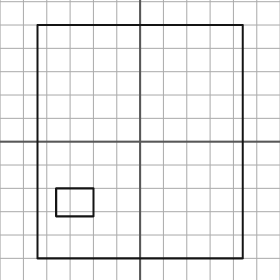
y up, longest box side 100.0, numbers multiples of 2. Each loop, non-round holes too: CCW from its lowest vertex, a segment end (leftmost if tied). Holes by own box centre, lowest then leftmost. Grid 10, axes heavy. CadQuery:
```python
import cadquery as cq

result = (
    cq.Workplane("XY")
    .moveTo(-44.0, -50.0)
    .lineTo(44.0, -50.0)
    .lineTo(44.0, 50.0)
    .lineTo(-44.0, 50.0)
    .close()
    .moveTo(-36.0, -32.0)
    .lineTo(-20.0, -32.0)
    .lineTo(-20.0, -20.0)
    .lineTo(-36.0, -20.0)
    .close()
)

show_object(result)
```